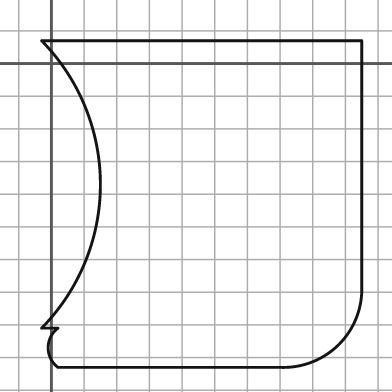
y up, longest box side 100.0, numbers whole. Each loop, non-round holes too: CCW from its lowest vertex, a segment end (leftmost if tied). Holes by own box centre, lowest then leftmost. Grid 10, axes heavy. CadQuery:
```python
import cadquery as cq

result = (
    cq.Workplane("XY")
    .moveTo(2.0, -93.0)
    .lineTo(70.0, -93.0)
    .threePointArc((88.0, -86.0), (95.0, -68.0))
    .lineTo(95.0, 7.0)
    .lineTo(-3.0, 7.0)
    .threePointArc((15.0, -37.0), (-3.0, -81.0))
    .lineTo(2.0, -81.0)
    .threePointArc((-1.0, -87.0), (2.0, -93.0))
    .close()
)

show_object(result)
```